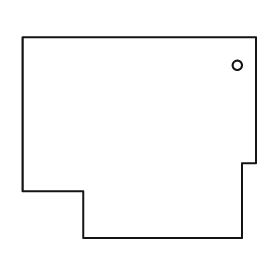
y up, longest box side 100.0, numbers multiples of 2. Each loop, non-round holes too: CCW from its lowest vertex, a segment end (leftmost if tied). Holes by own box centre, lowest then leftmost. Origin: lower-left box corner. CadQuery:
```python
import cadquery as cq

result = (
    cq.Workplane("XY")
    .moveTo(26.0, 0.0)
    .lineTo(94.0, 0.0)
    .lineTo(94.0, 32.0)
    .lineTo(100.0, 32.0)
    .lineTo(100.0, 86.0)
    .lineTo(0.0, 86.0)
    .lineTo(0.0, 20.0)
    .lineTo(26.0, 20.0)
    .close()
    .moveTo(92.0, 74.0)
    .circle(2.0)
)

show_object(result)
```